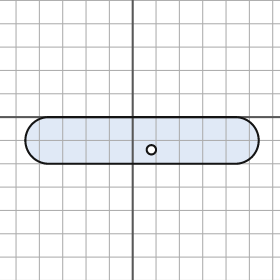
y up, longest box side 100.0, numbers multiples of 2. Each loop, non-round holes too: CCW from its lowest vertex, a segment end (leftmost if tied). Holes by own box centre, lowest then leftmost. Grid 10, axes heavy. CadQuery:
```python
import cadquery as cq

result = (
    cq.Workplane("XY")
    .moveTo(-36.0, -20.0)
    .lineTo(44.0, -20.0)
    .threePointArc((54.0, -10.0), (44.0, 0.0))
    .lineTo(-36.0, 0.0)
    .threePointArc((-46.0, -10.0), (-36.0, -20.0))
    .close()
    .moveTo(8.0, -14.0)
    .circle(2.0)
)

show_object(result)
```